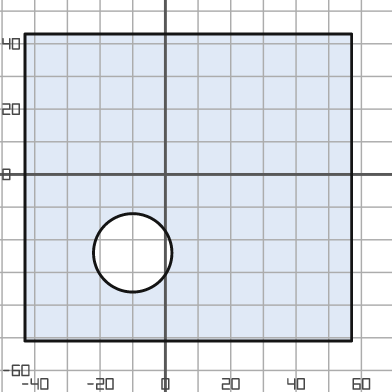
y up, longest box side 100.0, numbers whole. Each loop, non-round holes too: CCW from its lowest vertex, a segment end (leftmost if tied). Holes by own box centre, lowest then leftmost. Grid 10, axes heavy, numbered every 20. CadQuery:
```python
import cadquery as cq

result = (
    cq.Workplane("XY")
    .moveTo(-43.0, -51.0)
    .lineTo(57.0, -51.0)
    .lineTo(57.0, 43.0)
    .lineTo(-43.0, 43.0)
    .close()
    .moveTo(-10.0, -24.0)
    .circle(12.0)
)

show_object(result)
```